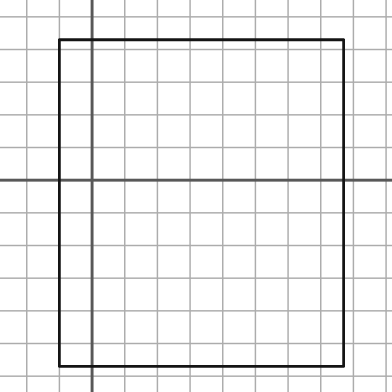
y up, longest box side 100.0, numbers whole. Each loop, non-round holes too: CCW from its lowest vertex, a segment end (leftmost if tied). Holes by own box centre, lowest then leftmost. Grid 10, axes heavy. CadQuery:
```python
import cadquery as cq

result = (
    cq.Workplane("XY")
    .moveTo(-10.0, -57.0)
    .lineTo(77.0, -57.0)
    .lineTo(77.0, 43.0)
    .lineTo(-10.0, 43.0)
    .close()
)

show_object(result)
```